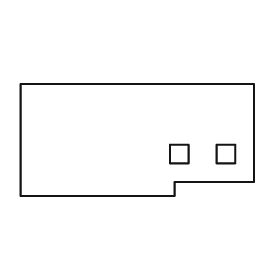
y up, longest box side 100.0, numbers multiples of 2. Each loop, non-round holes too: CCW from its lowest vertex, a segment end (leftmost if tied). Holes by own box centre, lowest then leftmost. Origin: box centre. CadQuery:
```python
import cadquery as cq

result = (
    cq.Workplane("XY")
    .moveTo(-50.0, -24.0)
    .lineTo(16.0, -24.0)
    .lineTo(16.0, -18.0)
    .lineTo(50.0, -18.0)
    .lineTo(50.0, 24.0)
    .lineTo(-50.0, 24.0)
    .close()
    .moveTo(14.0, -10.0)
    .lineTo(22.0, -10.0)
    .lineTo(22.0, -2.0)
    .lineTo(14.0, -2.0)
    .close()
    .moveTo(34.0, -10.0)
    .lineTo(42.0, -10.0)
    .lineTo(42.0, -2.0)
    .lineTo(34.0, -2.0)
    .close()
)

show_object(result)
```